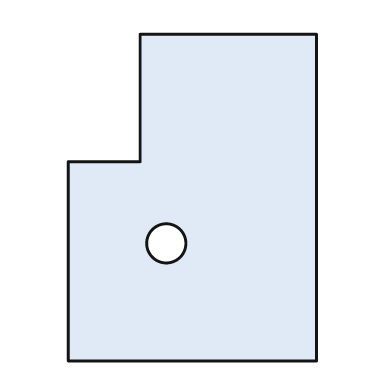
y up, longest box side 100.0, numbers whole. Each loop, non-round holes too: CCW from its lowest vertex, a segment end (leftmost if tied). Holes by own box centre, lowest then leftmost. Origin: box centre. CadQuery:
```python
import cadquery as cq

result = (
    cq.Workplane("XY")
    .moveTo(-38.0, -50.0)
    .lineTo(38.0, -50.0)
    .lineTo(38.0, 50.0)
    .lineTo(-16.0, 50.0)
    .lineTo(-16.0, 11.0)
    .lineTo(-38.0, 11.0)
    .close()
    .moveTo(-8.0, -14.0)
    .circle(6.0)
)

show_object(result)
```